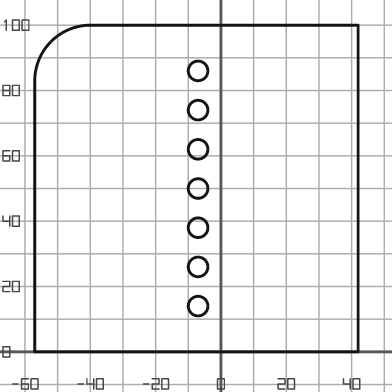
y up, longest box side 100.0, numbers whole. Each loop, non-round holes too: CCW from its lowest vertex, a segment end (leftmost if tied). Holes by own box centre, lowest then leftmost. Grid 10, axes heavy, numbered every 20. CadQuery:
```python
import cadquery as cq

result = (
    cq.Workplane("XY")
    .moveTo(-57.0, 0.0)
    .lineTo(42.0, 0.0)
    .lineTo(42.0, 100.0)
    .lineTo(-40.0, 100.0)
    .threePointArc((-52.0, 95.0), (-57.0, 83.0))
    .close()
    .moveTo(-7.0, 14.0)
    .circle(3.0)
    .moveTo(-7.0, 26.0)
    .circle(3.0)
    .moveTo(-7.0, 38.0)
    .circle(3.0)
    .moveTo(-7.0, 50.0)
    .circle(3.0)
    .moveTo(-7.0, 62.0)
    .circle(3.0)
    .moveTo(-7.0, 74.0)
    .circle(3.0)
    .moveTo(-7.0, 86.0)
    .circle(3.0)
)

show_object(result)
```